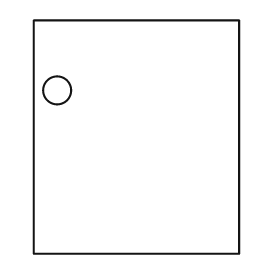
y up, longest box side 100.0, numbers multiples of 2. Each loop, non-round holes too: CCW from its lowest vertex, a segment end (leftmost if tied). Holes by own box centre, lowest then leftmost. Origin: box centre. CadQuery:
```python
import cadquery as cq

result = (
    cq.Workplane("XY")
    .moveTo(-44.0, -50.0)
    .lineTo(44.0, -50.0)
    .lineTo(44.0, 50.0)
    .lineTo(-44.0, 50.0)
    .close()
    .moveTo(-34.0, 20.0)
    .circle(6.0)
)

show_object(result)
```